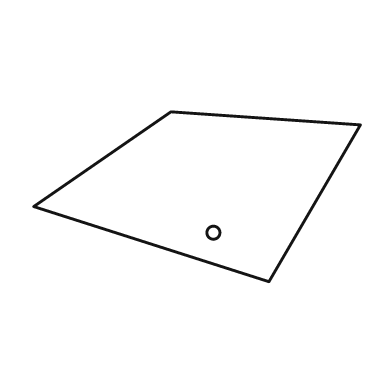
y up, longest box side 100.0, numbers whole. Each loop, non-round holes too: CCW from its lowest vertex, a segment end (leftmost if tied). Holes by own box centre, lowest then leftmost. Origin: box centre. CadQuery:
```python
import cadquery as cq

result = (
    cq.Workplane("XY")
    .moveTo(22.0, -26.0)
    .lineTo(50.0, 22.0)
    .lineTo(-8.0, 26.0)
    .lineTo(-50.0, -3.0)
    .close()
    .moveTo(5.0, -11.0)
    .circle(2.0)
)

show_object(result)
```